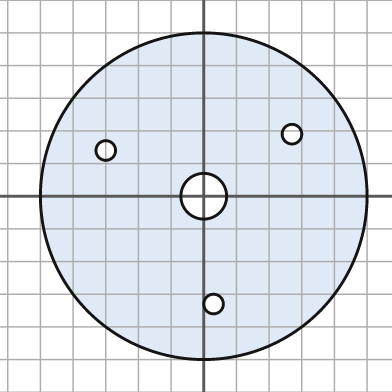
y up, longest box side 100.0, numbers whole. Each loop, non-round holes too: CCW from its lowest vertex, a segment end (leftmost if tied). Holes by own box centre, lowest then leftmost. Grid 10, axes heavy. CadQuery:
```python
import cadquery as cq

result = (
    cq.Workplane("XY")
    .moveTo(0.0, 0.0)
    .circle(50.0)
    .moveTo(3.0, -33.0)
    .circle(3.0)
    .moveTo(0.0, 0.0)
    .circle(7.0)
    .moveTo(-30.0, 14.0)
    .circle(3.0)
    .moveTo(27.0, 19.0)
    .circle(3.0)
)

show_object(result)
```